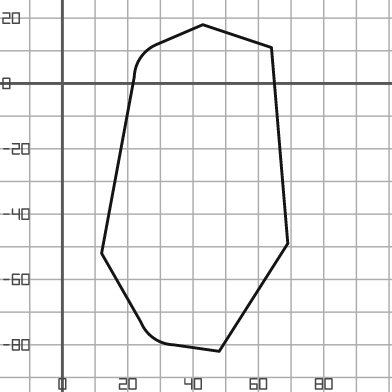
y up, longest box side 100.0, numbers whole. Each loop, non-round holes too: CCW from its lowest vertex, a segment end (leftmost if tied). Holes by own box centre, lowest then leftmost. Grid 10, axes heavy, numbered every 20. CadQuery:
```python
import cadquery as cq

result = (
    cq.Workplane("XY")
    .moveTo(48.0, -82.0)
    .lineTo(69.0, -49.0)
    .lineTo(64.0, 11.0)
    .lineTo(43.0, 18.0)
    .lineTo(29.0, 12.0)
    .threePointArc((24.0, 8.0), (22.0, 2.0))
    .lineTo(12.0, -52.0)
    .lineTo(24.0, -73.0)
    .threePointArc((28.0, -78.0), (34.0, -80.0))
    .close()
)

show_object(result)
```